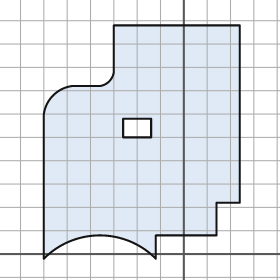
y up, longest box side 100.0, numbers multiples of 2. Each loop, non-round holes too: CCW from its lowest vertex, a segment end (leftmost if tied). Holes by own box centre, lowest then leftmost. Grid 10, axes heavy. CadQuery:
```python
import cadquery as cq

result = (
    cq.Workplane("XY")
    .moveTo(-60.0, -2.0)
    .threePointArc((-36.0, 8.0), (-12.0, -2.0))
    .lineTo(-12.0, 8.0)
    .lineTo(14.0, 8.0)
    .lineTo(14.0, 22.0)
    .lineTo(24.0, 22.0)
    .lineTo(24.0, 98.0)
    .lineTo(-30.0, 98.0)
    .lineTo(-30.0, 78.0)
    .threePointArc((-32.0, 74.0), (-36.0, 72.0))
    .lineTo(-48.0, 72.0)
    .threePointArc((-56.0, 68.0), (-60.0, 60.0))
    .close()
    .moveTo(-26.0, 50.0)
    .lineTo(-14.0, 50.0)
    .lineTo(-14.0, 58.0)
    .lineTo(-26.0, 58.0)
    .close()
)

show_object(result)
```